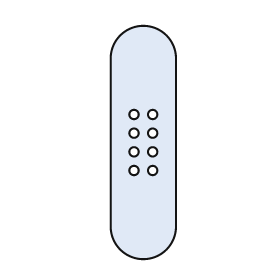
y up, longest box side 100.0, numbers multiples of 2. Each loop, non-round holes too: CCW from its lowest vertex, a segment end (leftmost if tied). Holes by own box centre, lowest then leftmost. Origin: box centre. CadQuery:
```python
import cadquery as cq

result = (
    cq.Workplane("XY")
    .moveTo(-14.0, -36.0)
    .threePointArc((0.0, -50.0), (14.0, -36.0))
    .lineTo(14.0, 36.0)
    .threePointArc((0.0, 50.0), (-14.0, 36.0))
    .close()
    .moveTo(-4.0, -12.0)
    .circle(2.0)
    .moveTo(4.0, -12.0)
    .circle(2.0)
    .moveTo(-4.0, -4.0)
    .circle(2.0)
    .moveTo(4.0, -4.0)
    .circle(2.0)
    .moveTo(-4.0, 4.0)
    .circle(2.0)
    .moveTo(4.0, 4.0)
    .circle(2.0)
    .moveTo(-4.0, 12.0)
    .circle(2.0)
    .moveTo(4.0, 12.0)
    .circle(2.0)
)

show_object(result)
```